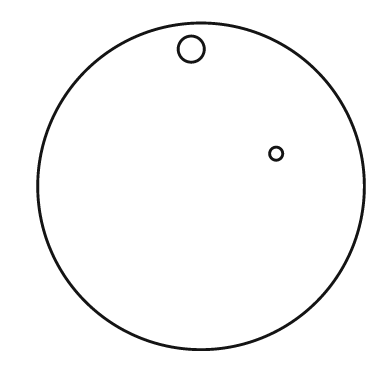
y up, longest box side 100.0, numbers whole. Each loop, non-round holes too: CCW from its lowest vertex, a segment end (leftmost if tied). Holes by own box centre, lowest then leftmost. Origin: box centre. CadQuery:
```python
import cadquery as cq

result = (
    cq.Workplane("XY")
    .moveTo(0.0, 0.0)
    .circle(50.0)
    .moveTo(23.0, 10.0)
    .circle(2.0)
    .moveTo(-3.0, 42.0)
    .circle(4.0)
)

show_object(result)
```